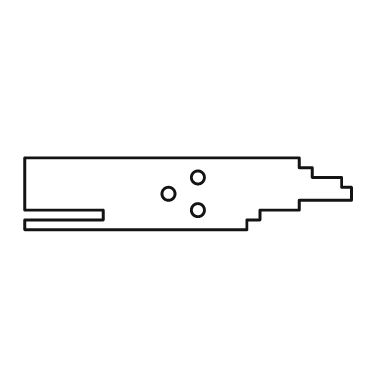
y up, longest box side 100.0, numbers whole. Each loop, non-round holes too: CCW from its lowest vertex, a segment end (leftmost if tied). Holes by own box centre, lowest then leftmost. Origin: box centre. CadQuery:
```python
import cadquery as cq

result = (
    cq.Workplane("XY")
    .moveTo(-50.0, -11.0)
    .lineTo(18.0, -11.0)
    .lineTo(18.0, -8.0)
    .lineTo(22.0, -8.0)
    .lineTo(22.0, -5.0)
    .lineTo(34.0, -5.0)
    .lineTo(34.0, -2.0)
    .lineTo(50.0, -2.0)
    .lineTo(50.0, 2.0)
    .lineTo(47.0, 2.0)
    .lineTo(47.0, 5.0)
    .lineTo(38.0, 5.0)
    .lineTo(38.0, 8.0)
    .lineTo(34.0, 8.0)
    .lineTo(34.0, 11.0)
    .lineTo(-50.0, 11.0)
    .lineTo(-50.0, -5.0)
    .lineTo(-26.0, -5.0)
    .lineTo(-26.0, -8.0)
    .lineTo(-50.0, -8.0)
    .close()
    .moveTo(3.0, -5.0)
    .circle(2.0)
    .moveTo(-6.0, 0.0)
    .circle(2.0)
    .moveTo(3.0, 5.0)
    .circle(2.0)
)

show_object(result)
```